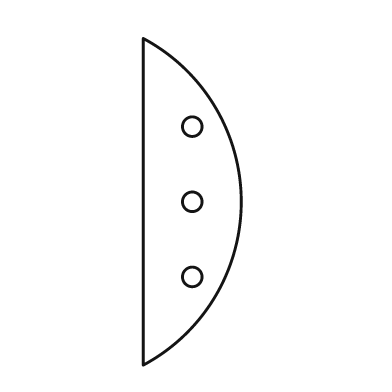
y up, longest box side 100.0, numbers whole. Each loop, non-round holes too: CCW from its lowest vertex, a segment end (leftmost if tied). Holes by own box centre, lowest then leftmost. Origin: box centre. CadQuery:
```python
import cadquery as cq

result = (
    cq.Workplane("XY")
    .moveTo(-15.0, -50.0)
    .threePointArc((15.0, 0.0), (-15.0, 50.0))
    .close()
    .moveTo(0.0, -23.0)
    .circle(3.0)
    .moveTo(0.0, 0.0)
    .circle(3.0)
    .moveTo(0.0, 23.0)
    .circle(3.0)
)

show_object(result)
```